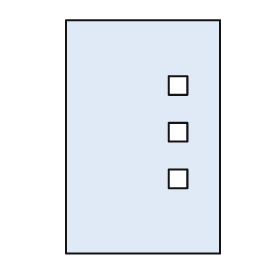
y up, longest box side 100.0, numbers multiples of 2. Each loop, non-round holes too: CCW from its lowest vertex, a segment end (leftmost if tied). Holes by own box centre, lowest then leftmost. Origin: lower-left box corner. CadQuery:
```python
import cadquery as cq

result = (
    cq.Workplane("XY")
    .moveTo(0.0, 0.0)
    .lineTo(66.0, 0.0)
    .lineTo(66.0, 100.0)
    .lineTo(0.0, 100.0)
    .close()
    .moveTo(44.0, 28.0)
    .lineTo(52.0, 28.0)
    .lineTo(52.0, 36.0)
    .lineTo(44.0, 36.0)
    .close()
    .moveTo(44.0, 48.0)
    .lineTo(52.0, 48.0)
    .lineTo(52.0, 56.0)
    .lineTo(44.0, 56.0)
    .close()
    .moveTo(44.0, 68.0)
    .lineTo(52.0, 68.0)
    .lineTo(52.0, 76.0)
    .lineTo(44.0, 76.0)
    .close()
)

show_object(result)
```